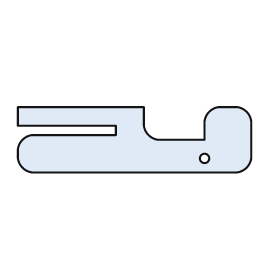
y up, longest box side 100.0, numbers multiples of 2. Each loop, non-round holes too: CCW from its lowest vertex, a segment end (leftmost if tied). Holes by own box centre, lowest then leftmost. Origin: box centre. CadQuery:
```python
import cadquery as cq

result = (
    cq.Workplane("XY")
    .moveTo(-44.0, -14.0)
    .lineTo(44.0, -14.0)
    .threePointArc((48.0, -12.0), (50.0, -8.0))
    .lineTo(50.0, 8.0)
    .threePointArc((48.0, 12.0), (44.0, 14.0))
    .lineTo(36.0, 14.0)
    .threePointArc((32.0, 12.0), (30.0, 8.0))
    .lineTo(30.0, 0.0)
    .lineTo(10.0, 0.0)
    .threePointArc((6.0, 2.0), (4.0, 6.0))
    .lineTo(4.0, 14.0)
    .lineTo(-50.0, 14.0)
    .lineTo(-50.0, 6.0)
    .lineTo(-8.0, 6.0)
    .lineTo(-8.0, 2.0)
    .lineTo(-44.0, 2.0)
    .threePointArc((-48.0, 0.0), (-50.0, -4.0))
    .lineTo(-50.0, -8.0)
    .threePointArc((-48.0, -12.0), (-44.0, -14.0))
    .close()
    .moveTo(30.0, -8.0)
    .circle(2.0)
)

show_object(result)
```